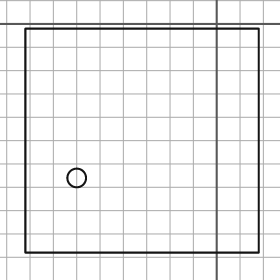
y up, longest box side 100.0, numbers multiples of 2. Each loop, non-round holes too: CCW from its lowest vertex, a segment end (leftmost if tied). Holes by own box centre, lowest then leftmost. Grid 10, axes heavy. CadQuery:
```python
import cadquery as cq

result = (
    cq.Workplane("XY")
    .moveTo(-82.0, -98.0)
    .lineTo(18.0, -98.0)
    .lineTo(18.0, -2.0)
    .lineTo(-82.0, -2.0)
    .close()
    .moveTo(-60.0, -66.0)
    .circle(4.0)
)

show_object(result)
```